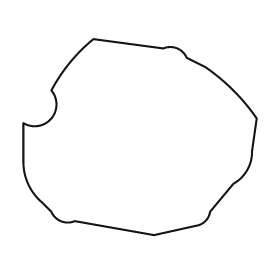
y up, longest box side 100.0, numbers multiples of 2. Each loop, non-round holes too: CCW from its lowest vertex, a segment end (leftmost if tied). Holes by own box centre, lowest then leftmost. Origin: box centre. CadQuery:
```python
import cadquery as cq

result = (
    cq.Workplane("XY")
    .moveTo(6.0, -42.0)
    .lineTo(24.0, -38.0)
    .threePointArc((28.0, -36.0), (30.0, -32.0))
    .lineTo(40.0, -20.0)
    .threePointArc((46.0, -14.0), (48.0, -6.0))
    .lineTo(50.0, 8.0)
    .threePointArc((40.0, 20.0), (28.0, 30.0))
    .lineTo(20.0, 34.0)
    .threePointArc((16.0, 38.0), (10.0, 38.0))
    .lineTo(-20.0, 42.0)
    .threePointArc((-30.0, 32.0), (-38.0, 20.0))
    .threePointArc((-38.0, 8.0), (-50.0, 6.0))
    .lineTo(-50.0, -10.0)
    .threePointArc((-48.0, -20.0), (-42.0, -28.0))
    .lineTo(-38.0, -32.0)
    .threePointArc((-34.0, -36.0), (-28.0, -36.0))
    .close()
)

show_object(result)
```